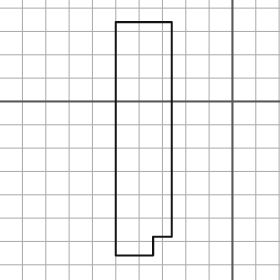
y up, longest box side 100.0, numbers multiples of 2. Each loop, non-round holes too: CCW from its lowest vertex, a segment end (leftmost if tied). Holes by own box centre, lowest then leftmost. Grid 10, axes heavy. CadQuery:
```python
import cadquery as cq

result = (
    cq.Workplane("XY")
    .moveTo(-50.0, -66.0)
    .lineTo(-34.0, -66.0)
    .lineTo(-34.0, -58.0)
    .lineTo(-26.0, -58.0)
    .lineTo(-26.0, 34.0)
    .lineTo(-50.0, 34.0)
    .close()
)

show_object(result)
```